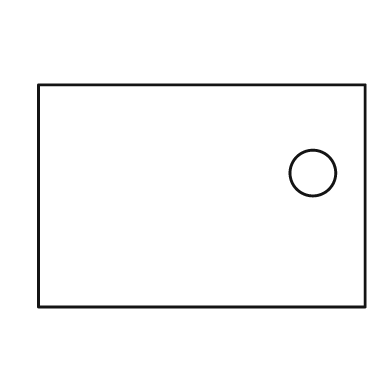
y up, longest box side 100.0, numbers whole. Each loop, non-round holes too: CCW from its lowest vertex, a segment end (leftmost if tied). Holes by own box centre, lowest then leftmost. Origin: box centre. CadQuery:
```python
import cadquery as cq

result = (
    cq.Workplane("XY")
    .moveTo(-50.0, -34.0)
    .lineTo(50.0, -34.0)
    .lineTo(50.0, 34.0)
    .lineTo(-50.0, 34.0)
    .close()
    .moveTo(34.0, 7.0)
    .circle(7.0)
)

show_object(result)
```